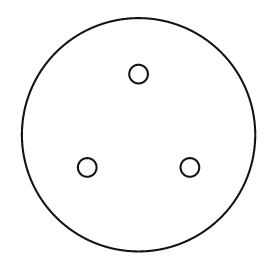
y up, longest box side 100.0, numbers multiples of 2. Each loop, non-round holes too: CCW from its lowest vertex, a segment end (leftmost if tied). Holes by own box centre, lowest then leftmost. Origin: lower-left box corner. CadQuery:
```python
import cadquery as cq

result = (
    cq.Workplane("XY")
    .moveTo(50.0, 50.0)
    .circle(50.0)
    .moveTo(28.0, 36.0)
    .circle(4.0)
    .moveTo(72.0, 36.0)
    .circle(4.0)
    .moveTo(50.0, 76.0)
    .circle(4.0)
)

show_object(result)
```